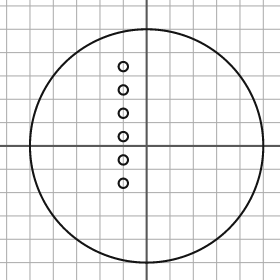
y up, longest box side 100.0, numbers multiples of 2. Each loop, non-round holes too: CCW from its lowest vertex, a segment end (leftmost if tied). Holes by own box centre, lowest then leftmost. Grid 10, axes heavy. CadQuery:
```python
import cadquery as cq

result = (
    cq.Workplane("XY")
    .moveTo(0.0, 0.0)
    .circle(50.0)
    .moveTo(-10.0, -16.0)
    .circle(2.0)
    .moveTo(-10.0, -6.0)
    .circle(2.0)
    .moveTo(-10.0, 4.0)
    .circle(2.0)
    .moveTo(-10.0, 14.0)
    .circle(2.0)
    .moveTo(-10.0, 24.0)
    .circle(2.0)
    .moveTo(-10.0, 34.0)
    .circle(2.0)
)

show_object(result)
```